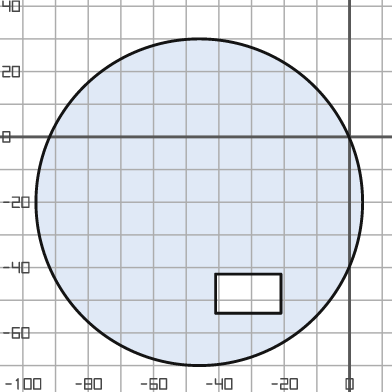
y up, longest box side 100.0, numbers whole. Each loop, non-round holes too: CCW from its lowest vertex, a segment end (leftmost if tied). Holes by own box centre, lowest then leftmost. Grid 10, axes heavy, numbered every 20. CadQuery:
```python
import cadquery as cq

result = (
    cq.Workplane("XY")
    .moveTo(-46.0, -20.0)
    .circle(50.0)
    .moveTo(-41.0, -54.0)
    .lineTo(-21.0, -54.0)
    .lineTo(-21.0, -42.0)
    .lineTo(-41.0, -42.0)
    .close()
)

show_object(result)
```